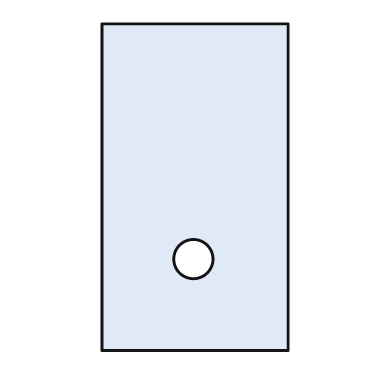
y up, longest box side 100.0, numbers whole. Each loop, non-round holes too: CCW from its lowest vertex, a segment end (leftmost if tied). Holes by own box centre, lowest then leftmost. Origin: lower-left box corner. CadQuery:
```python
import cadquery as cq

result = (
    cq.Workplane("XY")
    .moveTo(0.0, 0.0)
    .lineTo(57.0, 0.0)
    .lineTo(57.0, 100.0)
    .lineTo(0.0, 100.0)
    .close()
    .moveTo(28.0, 28.0)
    .circle(6.0)
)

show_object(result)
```